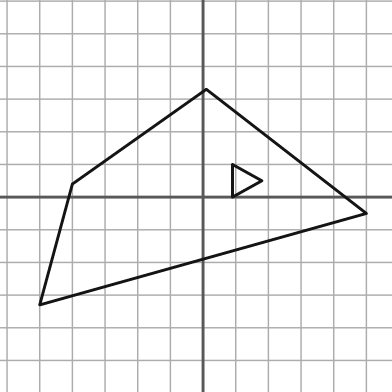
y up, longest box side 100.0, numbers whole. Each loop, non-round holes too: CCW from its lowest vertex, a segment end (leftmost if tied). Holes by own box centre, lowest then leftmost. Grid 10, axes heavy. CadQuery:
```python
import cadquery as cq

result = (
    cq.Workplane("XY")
    .moveTo(-50.0, -33.0)
    .lineTo(50.0, -5.0)
    .lineTo(1.0, 33.0)
    .lineTo(-40.0, 4.0)
    .close()
    .moveTo(9.0, 0.0)
    .lineTo(18.0, 5.0)
    .lineTo(9.0, 10.0)
    .close()
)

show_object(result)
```